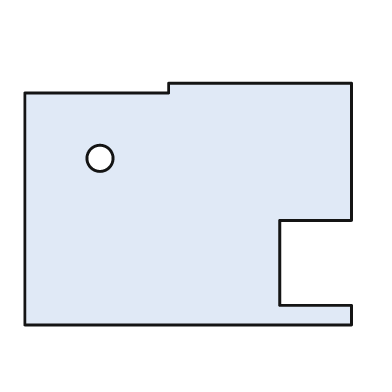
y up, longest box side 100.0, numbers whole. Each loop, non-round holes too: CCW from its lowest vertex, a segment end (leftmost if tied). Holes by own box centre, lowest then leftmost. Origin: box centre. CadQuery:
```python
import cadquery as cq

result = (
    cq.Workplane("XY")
    .moveTo(-50.0, -37.0)
    .lineTo(50.0, -37.0)
    .lineTo(50.0, -31.0)
    .lineTo(28.0, -31.0)
    .lineTo(28.0, -5.0)
    .lineTo(50.0, -5.0)
    .lineTo(50.0, 37.0)
    .lineTo(-6.0, 37.0)
    .lineTo(-6.0, 34.0)
    .lineTo(-50.0, 34.0)
    .close()
    .moveTo(-27.0, 14.0)
    .circle(4.0)
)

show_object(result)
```